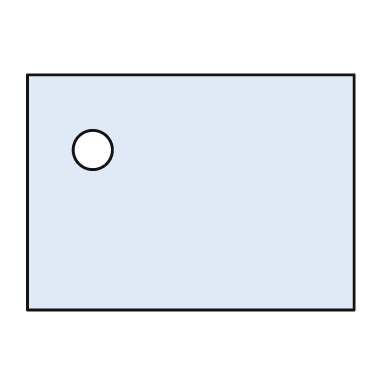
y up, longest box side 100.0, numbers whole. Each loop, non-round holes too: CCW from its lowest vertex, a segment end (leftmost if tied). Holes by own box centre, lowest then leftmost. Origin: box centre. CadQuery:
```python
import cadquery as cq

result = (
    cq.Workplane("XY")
    .moveTo(-50.0, -36.0)
    .lineTo(50.0, -36.0)
    .lineTo(50.0, 36.0)
    .lineTo(-50.0, 36.0)
    .close()
    .moveTo(-30.0, 13.0)
    .circle(6.0)
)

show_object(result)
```